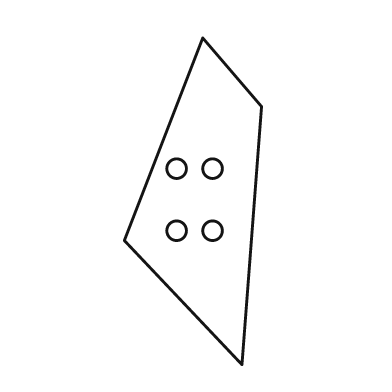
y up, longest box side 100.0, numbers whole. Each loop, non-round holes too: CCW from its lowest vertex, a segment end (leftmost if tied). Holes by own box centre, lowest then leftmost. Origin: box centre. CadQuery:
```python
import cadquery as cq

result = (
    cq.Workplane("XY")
    .moveTo(15.0, -50.0)
    .lineTo(21.0, 29.0)
    .lineTo(3.0, 50.0)
    .lineTo(-21.0, -12.0)
    .close()
    .moveTo(-5.0, -9.0)
    .circle(3.0)
    .moveTo(6.0, -9.0)
    .circle(3.0)
    .moveTo(-5.0, 10.0)
    .circle(3.0)
    .moveTo(6.0, 10.0)
    .circle(3.0)
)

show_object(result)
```